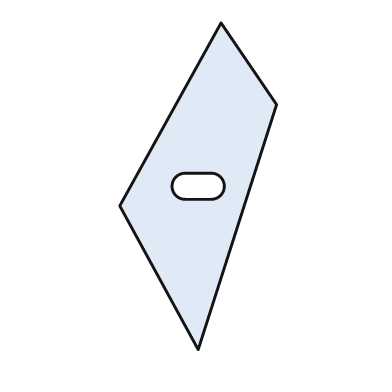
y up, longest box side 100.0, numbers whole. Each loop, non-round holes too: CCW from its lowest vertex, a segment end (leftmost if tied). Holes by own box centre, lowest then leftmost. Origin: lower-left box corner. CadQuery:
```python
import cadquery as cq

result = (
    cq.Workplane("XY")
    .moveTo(24.0, 0.0)
    .lineTo(48.0, 75.0)
    .lineTo(31.0, 100.0)
    .lineTo(0.0, 44.0)
    .close()
    .moveTo(20.0, 46.0)
    .lineTo(28.0, 46.0)
    .threePointArc((32.0, 50.0), (28.0, 54.0))
    .lineTo(20.0, 54.0)
    .threePointArc((16.0, 50.0), (20.0, 46.0))
    .close()
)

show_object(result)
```